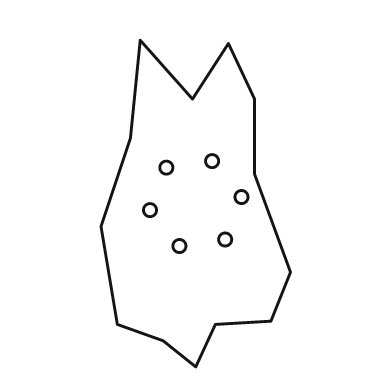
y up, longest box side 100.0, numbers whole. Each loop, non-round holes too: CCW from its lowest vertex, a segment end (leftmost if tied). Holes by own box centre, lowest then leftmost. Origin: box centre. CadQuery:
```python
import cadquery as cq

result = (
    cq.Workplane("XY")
    .moveTo(0.0, -50.0)
    .lineTo(6.0, -37.0)
    .lineTo(23.0, -36.0)
    .lineTo(29.0, -21.0)
    .lineTo(18.0, 9.0)
    .lineTo(18.0, 32.0)
    .lineTo(10.0, 49.0)
    .lineTo(-1.0, 32.0)
    .lineTo(-17.0, 50.0)
    .lineTo(-20.0, 20.0)
    .lineTo(-29.0, -7.0)
    .lineTo(-24.0, -37.0)
    .lineTo(-10.0, -42.0)
    .close()
    .moveTo(-5.0, -13.0)
    .circle(2.0)
    .moveTo(9.0, -11.0)
    .circle(2.0)
    .moveTo(-14.0, -2.0)
    .circle(2.0)
    .moveTo(14.0, 2.0)
    .circle(2.0)
    .moveTo(-9.0, 11.0)
    .circle(2.0)
    .moveTo(5.0, 13.0)
    .circle(2.0)
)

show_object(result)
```